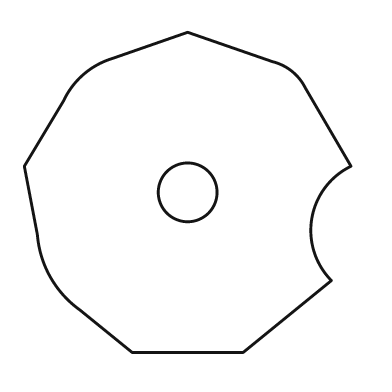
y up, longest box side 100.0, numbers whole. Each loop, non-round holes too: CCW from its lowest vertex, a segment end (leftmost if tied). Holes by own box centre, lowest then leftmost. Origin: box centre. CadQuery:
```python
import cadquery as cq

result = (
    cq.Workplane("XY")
    .moveTo(-17.0, -49.0)
    .lineTo(17.0, -49.0)
    .lineTo(44.0, -27.0)
    .threePointArc((38.0, -8.0), (50.0, 8.0))
    .lineTo(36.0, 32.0)
    .threePointArc((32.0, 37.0), (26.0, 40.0))
    .lineTo(0.0, 49.0)
    .lineTo(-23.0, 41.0)
    .threePointArc((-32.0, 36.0), (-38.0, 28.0))
    .lineTo(-50.0, 8.0)
    .lineTo(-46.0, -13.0)
    .threePointArc((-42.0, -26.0), (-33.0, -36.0))
    .close()
    .moveTo(0.0, 0.0)
    .circle(9.0)
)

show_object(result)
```